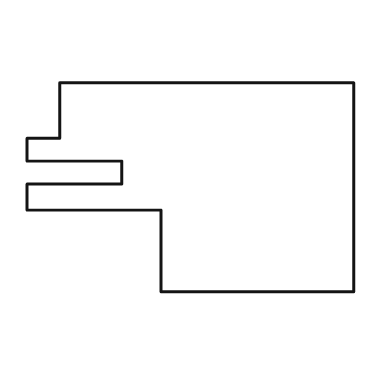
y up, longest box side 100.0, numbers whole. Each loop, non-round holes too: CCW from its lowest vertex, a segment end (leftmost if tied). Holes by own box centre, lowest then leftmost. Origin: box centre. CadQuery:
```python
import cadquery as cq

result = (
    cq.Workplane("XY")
    .moveTo(-9.0, -32.0)
    .lineTo(50.0, -32.0)
    .lineTo(50.0, 32.0)
    .lineTo(-40.0, 32.0)
    .lineTo(-40.0, 15.0)
    .lineTo(-50.0, 15.0)
    .lineTo(-50.0, 8.0)
    .lineTo(-21.0, 8.0)
    .lineTo(-21.0, 1.0)
    .lineTo(-50.0, 1.0)
    .lineTo(-50.0, -7.0)
    .lineTo(-9.0, -7.0)
    .close()
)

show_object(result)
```